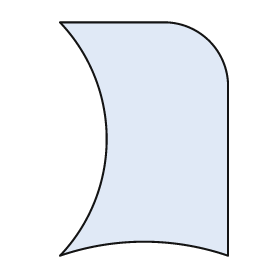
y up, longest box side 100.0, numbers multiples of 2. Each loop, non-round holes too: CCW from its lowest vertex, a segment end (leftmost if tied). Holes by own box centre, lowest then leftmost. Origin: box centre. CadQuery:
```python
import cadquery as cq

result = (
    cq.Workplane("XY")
    .moveTo(-36.0, -50.0)
    .threePointArc((0.0, -44.0), (36.0, -50.0))
    .lineTo(36.0, 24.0)
    .threePointArc((28.0, 42.0), (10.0, 50.0))
    .lineTo(-36.0, 50.0)
    .threePointArc((-16.0, 0.0), (-36.0, -50.0))
    .close()
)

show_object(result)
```